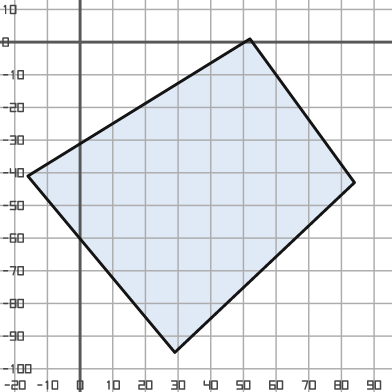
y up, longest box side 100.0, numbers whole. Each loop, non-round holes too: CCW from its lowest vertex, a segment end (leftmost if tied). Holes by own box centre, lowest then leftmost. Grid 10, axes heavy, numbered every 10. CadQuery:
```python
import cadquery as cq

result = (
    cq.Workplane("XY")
    .moveTo(29.0, -95.0)
    .lineTo(84.0, -43.0)
    .lineTo(52.0, 1.0)
    .lineTo(-16.0, -41.0)
    .close()
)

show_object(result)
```